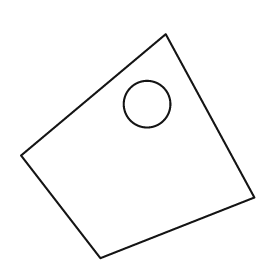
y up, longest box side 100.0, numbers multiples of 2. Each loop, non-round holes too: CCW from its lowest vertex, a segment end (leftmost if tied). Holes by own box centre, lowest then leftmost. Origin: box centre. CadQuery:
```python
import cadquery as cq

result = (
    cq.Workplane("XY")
    .moveTo(-16.0, -48.0)
    .lineTo(50.0, -22.0)
    .lineTo(12.0, 48.0)
    .lineTo(-50.0, -4.0)
    .close()
    .moveTo(4.0, 18.0)
    .circle(10.0)
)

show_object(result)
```